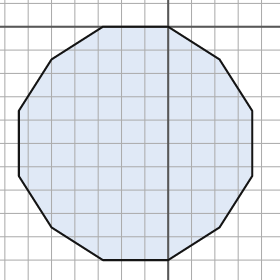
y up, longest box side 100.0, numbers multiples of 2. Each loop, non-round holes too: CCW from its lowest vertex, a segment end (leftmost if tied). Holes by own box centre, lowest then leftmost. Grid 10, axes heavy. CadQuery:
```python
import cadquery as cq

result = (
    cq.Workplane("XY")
    .moveTo(-28.0, -100.0)
    .lineTo(0.0, -100.0)
    .lineTo(22.0, -86.0)
    .lineTo(36.0, -64.0)
    .lineTo(36.0, -36.0)
    .lineTo(22.0, -14.0)
    .lineTo(0.0, 0.0)
    .lineTo(-28.0, 0.0)
    .lineTo(-50.0, -14.0)
    .lineTo(-64.0, -36.0)
    .lineTo(-64.0, -64.0)
    .lineTo(-50.0, -86.0)
    .close()
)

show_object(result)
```